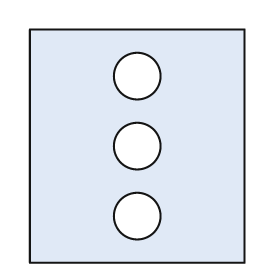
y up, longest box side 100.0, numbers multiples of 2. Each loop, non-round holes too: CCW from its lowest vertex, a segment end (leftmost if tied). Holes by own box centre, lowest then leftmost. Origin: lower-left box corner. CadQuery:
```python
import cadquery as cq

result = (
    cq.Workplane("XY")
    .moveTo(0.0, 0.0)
    .lineTo(92.0, 0.0)
    .lineTo(92.0, 100.0)
    .lineTo(0.0, 100.0)
    .close()
    .moveTo(46.0, 20.0)
    .circle(10.0)
    .moveTo(46.0, 50.0)
    .circle(10.0)
    .moveTo(46.0, 80.0)
    .circle(10.0)
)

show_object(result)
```